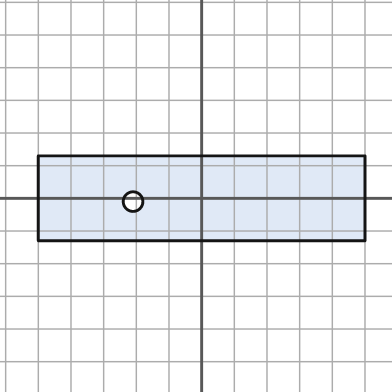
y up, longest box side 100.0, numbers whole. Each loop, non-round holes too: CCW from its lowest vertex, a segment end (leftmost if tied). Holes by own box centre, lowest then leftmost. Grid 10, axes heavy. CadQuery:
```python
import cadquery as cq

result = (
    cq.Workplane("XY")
    .moveTo(-50.0, -13.0)
    .lineTo(50.0, -13.0)
    .lineTo(50.0, 13.0)
    .lineTo(-50.0, 13.0)
    .close()
    .moveTo(-21.0, -1.0)
    .circle(3.0)
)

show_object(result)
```